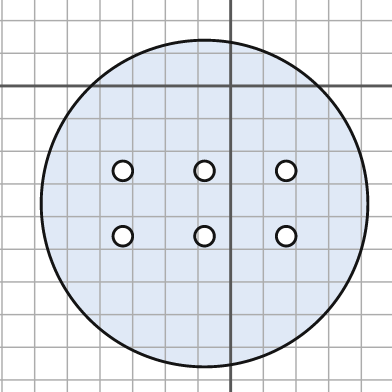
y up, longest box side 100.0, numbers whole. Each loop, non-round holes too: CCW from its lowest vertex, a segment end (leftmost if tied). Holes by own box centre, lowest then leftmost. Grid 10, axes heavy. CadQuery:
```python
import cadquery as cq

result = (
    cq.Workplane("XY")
    .moveTo(-8.0, -36.0)
    .circle(50.0)
    .moveTo(-33.0, -46.0)
    .circle(3.0)
    .moveTo(-8.0, -46.0)
    .circle(3.0)
    .moveTo(17.0, -46.0)
    .circle(3.0)
    .moveTo(-33.0, -26.0)
    .circle(3.0)
    .moveTo(-8.0, -26.0)
    .circle(3.0)
    .moveTo(17.0, -26.0)
    .circle(3.0)
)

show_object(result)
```